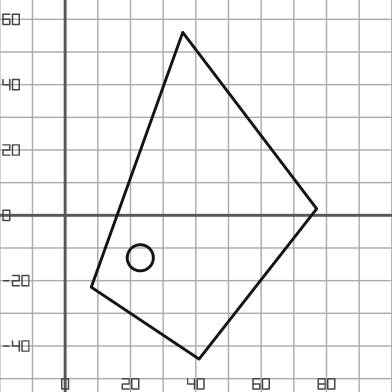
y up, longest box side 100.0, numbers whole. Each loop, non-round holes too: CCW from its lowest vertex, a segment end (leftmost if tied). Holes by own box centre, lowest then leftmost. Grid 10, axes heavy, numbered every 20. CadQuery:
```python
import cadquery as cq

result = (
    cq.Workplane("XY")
    .moveTo(41.0, -44.0)
    .lineTo(77.0, 2.0)
    .lineTo(36.0, 56.0)
    .lineTo(8.0, -22.0)
    .close()
    .moveTo(23.0, -13.0)
    .circle(4.0)
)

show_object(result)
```